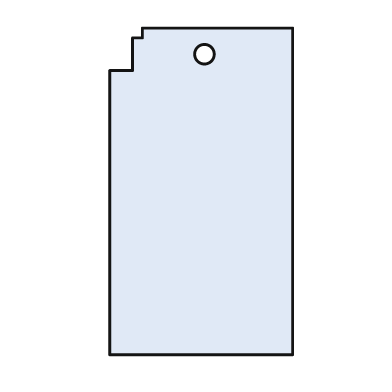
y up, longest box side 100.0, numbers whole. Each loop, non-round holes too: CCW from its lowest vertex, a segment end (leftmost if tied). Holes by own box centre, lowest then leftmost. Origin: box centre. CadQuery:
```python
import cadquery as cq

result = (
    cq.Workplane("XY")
    .moveTo(-28.0, -50.0)
    .lineTo(28.0, -50.0)
    .lineTo(28.0, 50.0)
    .lineTo(-18.0, 50.0)
    .lineTo(-18.0, 47.0)
    .lineTo(-21.0, 47.0)
    .lineTo(-21.0, 37.0)
    .lineTo(-28.0, 37.0)
    .close()
    .moveTo(1.0, 42.0)
    .circle(3.0)
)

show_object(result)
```